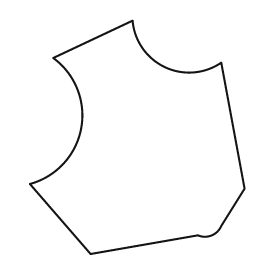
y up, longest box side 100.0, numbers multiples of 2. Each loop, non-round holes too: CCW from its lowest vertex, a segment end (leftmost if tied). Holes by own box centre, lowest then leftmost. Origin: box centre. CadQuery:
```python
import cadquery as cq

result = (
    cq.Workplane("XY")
    .moveTo(-20.0, -50.0)
    .lineTo(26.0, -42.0)
    .threePointArc((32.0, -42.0), (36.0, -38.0))
    .lineTo(46.0, -22.0)
    .lineTo(36.0, 32.0)
    .threePointArc((12.0, 30.0), (-2.0, 50.0))
    .lineTo(-36.0, 34.0)
    .threePointArc((-24.0, 4.0), (-46.0, -20.0))
    .close()
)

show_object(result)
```